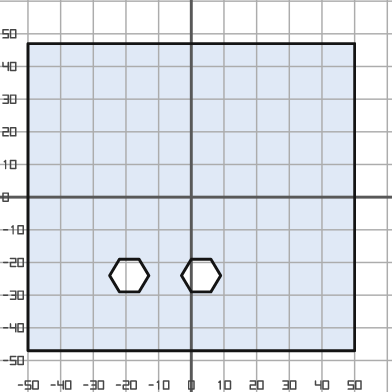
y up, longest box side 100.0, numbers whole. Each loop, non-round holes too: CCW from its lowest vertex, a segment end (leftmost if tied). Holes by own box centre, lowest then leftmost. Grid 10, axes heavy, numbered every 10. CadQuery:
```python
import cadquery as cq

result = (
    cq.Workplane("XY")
    .moveTo(-50.0, -47.0)
    .lineTo(50.0, -47.0)
    .lineTo(50.0, 47.0)
    .lineTo(-50.0, 47.0)
    .close()
    .moveTo(-22.0, -29.0)
    .lineTo(-16.0, -29.0)
    .lineTo(-13.0, -24.0)
    .lineTo(-16.0, -19.0)
    .lineTo(-22.0, -19.0)
    .lineTo(-25.0, -24.0)
    .close()
    .moveTo(0.0, -29.0)
    .lineTo(6.0, -29.0)
    .lineTo(9.0, -24.0)
    .lineTo(6.0, -19.0)
    .lineTo(0.0, -19.0)
    .lineTo(-3.0, -24.0)
    .close()
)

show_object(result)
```